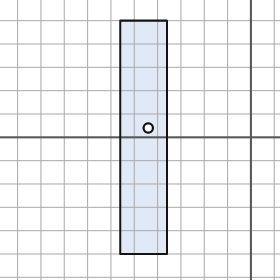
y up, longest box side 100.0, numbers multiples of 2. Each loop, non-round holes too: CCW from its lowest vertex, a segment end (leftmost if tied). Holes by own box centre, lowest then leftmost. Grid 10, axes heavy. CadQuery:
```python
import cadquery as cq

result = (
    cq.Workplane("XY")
    .moveTo(-56.0, -50.0)
    .lineTo(-36.0, -50.0)
    .lineTo(-36.0, 50.0)
    .lineTo(-56.0, 50.0)
    .close()
    .moveTo(-44.0, 4.0)
    .circle(2.0)
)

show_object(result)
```